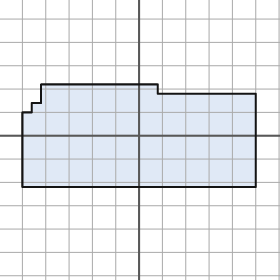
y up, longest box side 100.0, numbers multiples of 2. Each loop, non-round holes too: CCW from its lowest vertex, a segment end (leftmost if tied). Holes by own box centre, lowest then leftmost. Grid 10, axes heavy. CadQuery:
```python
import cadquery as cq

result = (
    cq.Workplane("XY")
    .moveTo(-50.0, -22.0)
    .lineTo(50.0, -22.0)
    .lineTo(50.0, 18.0)
    .lineTo(8.0, 18.0)
    .lineTo(8.0, 22.0)
    .lineTo(-42.0, 22.0)
    .lineTo(-42.0, 14.0)
    .lineTo(-46.0, 14.0)
    .lineTo(-46.0, 10.0)
    .lineTo(-50.0, 10.0)
    .close()
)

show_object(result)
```